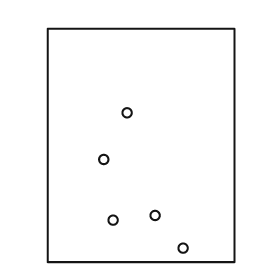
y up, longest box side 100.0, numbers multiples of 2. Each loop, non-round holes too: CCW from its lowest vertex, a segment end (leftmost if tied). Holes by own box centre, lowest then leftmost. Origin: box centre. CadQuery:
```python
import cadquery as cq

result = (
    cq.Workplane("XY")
    .moveTo(-40.0, -50.0)
    .lineTo(40.0, -50.0)
    .lineTo(40.0, 50.0)
    .lineTo(-40.0, 50.0)
    .close()
    .moveTo(18.0, -44.0)
    .circle(2.0)
    .moveTo(-12.0, -32.0)
    .circle(2.0)
    .moveTo(6.0, -30.0)
    .circle(2.0)
    .moveTo(-16.0, -6.0)
    .circle(2.0)
    .moveTo(-6.0, 14.0)
    .circle(2.0)
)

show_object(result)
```